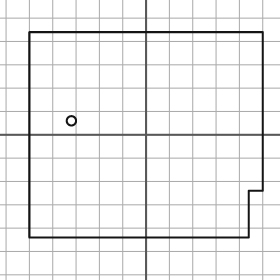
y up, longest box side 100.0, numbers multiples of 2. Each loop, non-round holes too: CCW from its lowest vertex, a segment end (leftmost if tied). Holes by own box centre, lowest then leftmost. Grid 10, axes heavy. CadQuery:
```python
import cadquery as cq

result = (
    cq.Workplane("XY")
    .moveTo(-50.0, -44.0)
    .lineTo(44.0, -44.0)
    .lineTo(44.0, -24.0)
    .lineTo(50.0, -24.0)
    .lineTo(50.0, 44.0)
    .lineTo(-50.0, 44.0)
    .close()
    .moveTo(-32.0, 6.0)
    .circle(2.0)
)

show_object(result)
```